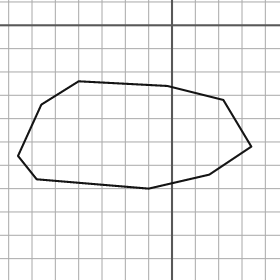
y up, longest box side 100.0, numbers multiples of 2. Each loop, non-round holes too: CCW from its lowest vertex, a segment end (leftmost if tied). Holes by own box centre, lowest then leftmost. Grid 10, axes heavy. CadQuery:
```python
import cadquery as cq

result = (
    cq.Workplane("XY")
    .moveTo(-10.0, -70.0)
    .lineTo(16.0, -64.0)
    .lineTo(34.0, -52.0)
    .lineTo(22.0, -32.0)
    .lineTo(-2.0, -26.0)
    .lineTo(-40.0, -24.0)
    .lineTo(-56.0, -34.0)
    .lineTo(-66.0, -56.0)
    .lineTo(-58.0, -66.0)
    .close()
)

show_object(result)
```